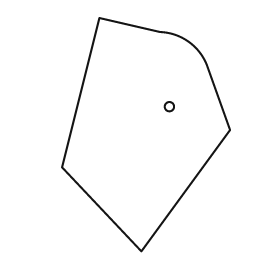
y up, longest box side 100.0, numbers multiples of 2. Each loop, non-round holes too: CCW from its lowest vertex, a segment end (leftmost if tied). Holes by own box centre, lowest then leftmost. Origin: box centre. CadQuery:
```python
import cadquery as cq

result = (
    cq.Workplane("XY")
    .moveTo(-2.0, -50.0)
    .lineTo(36.0, 2.0)
    .lineTo(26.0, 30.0)
    .threePointArc((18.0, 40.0), (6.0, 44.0))
    .lineTo(-20.0, 50.0)
    .lineTo(-36.0, -14.0)
    .close()
    .moveTo(10.0, 12.0)
    .circle(2.0)
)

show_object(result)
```